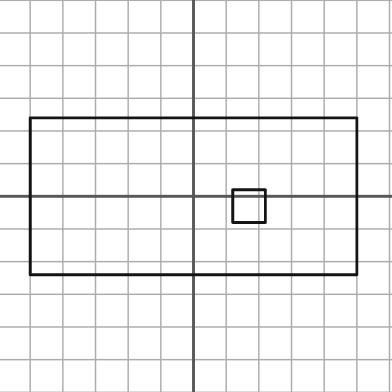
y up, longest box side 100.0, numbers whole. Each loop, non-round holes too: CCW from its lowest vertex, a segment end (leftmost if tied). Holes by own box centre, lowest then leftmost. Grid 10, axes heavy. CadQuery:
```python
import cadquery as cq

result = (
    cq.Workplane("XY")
    .moveTo(-50.0, -24.0)
    .lineTo(50.0, -24.0)
    .lineTo(50.0, 24.0)
    .lineTo(-50.0, 24.0)
    .close()
    .moveTo(12.0, -8.0)
    .lineTo(22.0, -8.0)
    .lineTo(22.0, 2.0)
    .lineTo(12.0, 2.0)
    .close()
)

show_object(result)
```